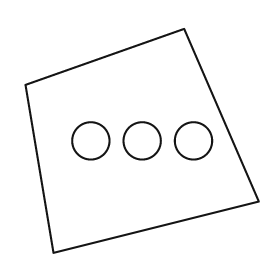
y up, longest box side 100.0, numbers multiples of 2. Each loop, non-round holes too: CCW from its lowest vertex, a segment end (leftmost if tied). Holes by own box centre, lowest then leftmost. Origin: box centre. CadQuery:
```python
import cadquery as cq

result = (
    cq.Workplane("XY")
    .moveTo(-38.0, -48.0)
    .lineTo(50.0, -26.0)
    .lineTo(18.0, 48.0)
    .lineTo(-50.0, 24.0)
    .close()
    .moveTo(-22.0, 0.0)
    .circle(8.0)
    .moveTo(0.0, 0.0)
    .circle(8.0)
    .moveTo(22.0, 0.0)
    .circle(8.0)
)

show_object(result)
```